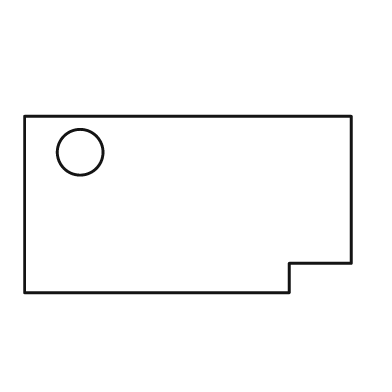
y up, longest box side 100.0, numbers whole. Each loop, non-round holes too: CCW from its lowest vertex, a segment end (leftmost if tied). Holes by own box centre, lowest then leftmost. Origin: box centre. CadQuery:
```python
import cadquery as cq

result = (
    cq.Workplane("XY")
    .moveTo(-50.0, -27.0)
    .lineTo(31.0, -27.0)
    .lineTo(31.0, -18.0)
    .lineTo(50.0, -18.0)
    .lineTo(50.0, 27.0)
    .lineTo(-50.0, 27.0)
    .close()
    .moveTo(-33.0, 16.0)
    .circle(7.0)
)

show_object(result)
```